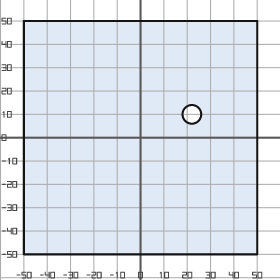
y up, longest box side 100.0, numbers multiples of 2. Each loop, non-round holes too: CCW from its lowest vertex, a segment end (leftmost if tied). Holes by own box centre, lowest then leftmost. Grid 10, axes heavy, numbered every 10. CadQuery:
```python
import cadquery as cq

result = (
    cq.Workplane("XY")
    .moveTo(-50.0, -50.0)
    .lineTo(50.0, -50.0)
    .lineTo(50.0, 50.0)
    .lineTo(-50.0, 50.0)
    .close()
    .moveTo(22.0, 10.0)
    .circle(4.0)
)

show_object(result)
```